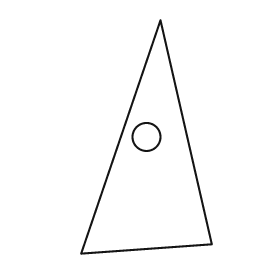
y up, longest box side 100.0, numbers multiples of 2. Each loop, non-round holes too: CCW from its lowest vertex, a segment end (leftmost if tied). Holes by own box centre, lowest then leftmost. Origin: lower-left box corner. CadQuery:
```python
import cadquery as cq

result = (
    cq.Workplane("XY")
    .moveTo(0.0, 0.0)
    .lineTo(56.0, 4.0)
    .lineTo(34.0, 100.0)
    .close()
    .moveTo(28.0, 50.0)
    .circle(6.0)
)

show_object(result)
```